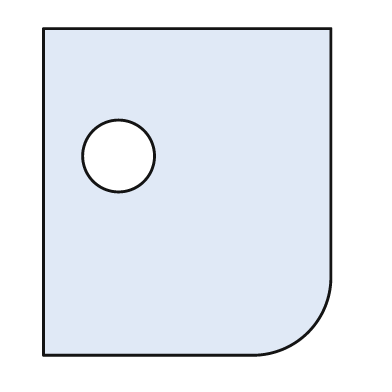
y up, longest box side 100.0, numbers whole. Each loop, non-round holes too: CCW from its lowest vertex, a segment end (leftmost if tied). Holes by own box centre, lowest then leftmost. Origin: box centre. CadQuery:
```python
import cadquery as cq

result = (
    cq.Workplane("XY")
    .moveTo(-44.0, -50.0)
    .lineTo(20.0, -50.0)
    .threePointArc((37.0, -43.0), (44.0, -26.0))
    .lineTo(44.0, 50.0)
    .lineTo(-44.0, 50.0)
    .close()
    .moveTo(-21.0, 11.0)
    .circle(11.0)
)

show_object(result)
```